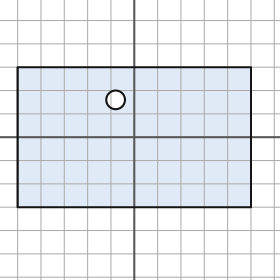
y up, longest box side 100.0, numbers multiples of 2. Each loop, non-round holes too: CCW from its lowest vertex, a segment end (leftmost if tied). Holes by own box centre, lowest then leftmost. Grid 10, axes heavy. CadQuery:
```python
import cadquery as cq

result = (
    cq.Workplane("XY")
    .moveTo(-50.0, -30.0)
    .lineTo(50.0, -30.0)
    .lineTo(50.0, 30.0)
    .lineTo(-50.0, 30.0)
    .close()
    .moveTo(-8.0, 16.0)
    .circle(4.0)
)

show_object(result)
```